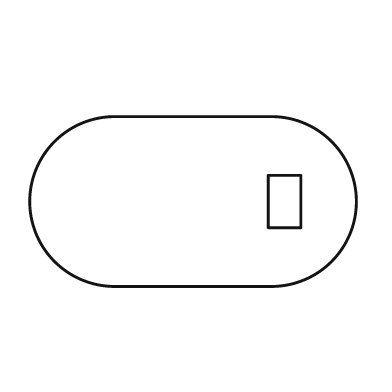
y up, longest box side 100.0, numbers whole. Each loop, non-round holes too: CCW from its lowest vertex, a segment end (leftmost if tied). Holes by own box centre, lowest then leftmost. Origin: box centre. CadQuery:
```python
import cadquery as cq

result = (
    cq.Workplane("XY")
    .moveTo(-24.0, -26.0)
    .lineTo(24.0, -26.0)
    .threePointArc((50.0, 0.0), (24.0, 26.0))
    .lineTo(-24.0, 26.0)
    .threePointArc((-50.0, 0.0), (-24.0, -26.0))
    .close()
    .moveTo(23.0, -8.0)
    .lineTo(33.0, -8.0)
    .lineTo(33.0, 8.0)
    .lineTo(23.0, 8.0)
    .close()
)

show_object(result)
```